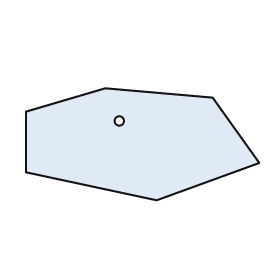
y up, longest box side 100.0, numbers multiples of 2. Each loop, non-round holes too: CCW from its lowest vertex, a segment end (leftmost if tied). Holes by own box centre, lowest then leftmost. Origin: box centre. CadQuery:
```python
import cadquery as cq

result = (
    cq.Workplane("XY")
    .moveTo(6.0, -24.0)
    .lineTo(50.0, -8.0)
    .lineTo(30.0, 20.0)
    .lineTo(-16.0, 24.0)
    .lineTo(-50.0, 14.0)
    .lineTo(-50.0, -12.0)
    .close()
    .moveTo(-10.0, 10.0)
    .circle(2.0)
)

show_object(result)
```